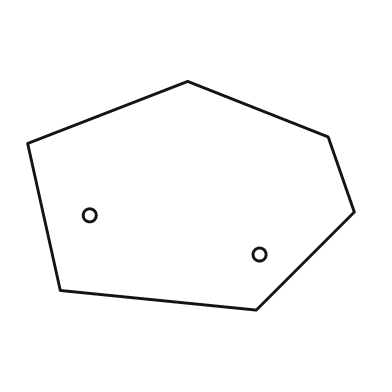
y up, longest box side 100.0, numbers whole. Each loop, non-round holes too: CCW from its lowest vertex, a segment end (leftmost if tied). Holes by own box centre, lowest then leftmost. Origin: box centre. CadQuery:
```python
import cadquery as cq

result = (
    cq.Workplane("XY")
    .moveTo(20.0, -35.0)
    .lineTo(50.0, -5.0)
    .lineTo(42.0, 18.0)
    .lineTo(-1.0, 35.0)
    .lineTo(-50.0, 16.0)
    .lineTo(-40.0, -29.0)
    .close()
    .moveTo(21.0, -18.0)
    .circle(2.0)
    .moveTo(-31.0, -6.0)
    .circle(2.0)
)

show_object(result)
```